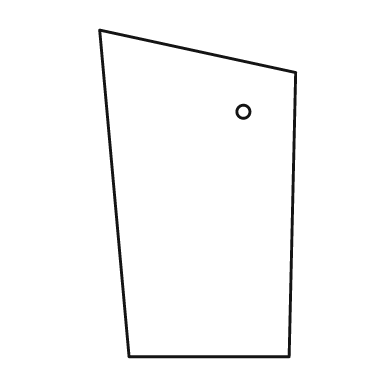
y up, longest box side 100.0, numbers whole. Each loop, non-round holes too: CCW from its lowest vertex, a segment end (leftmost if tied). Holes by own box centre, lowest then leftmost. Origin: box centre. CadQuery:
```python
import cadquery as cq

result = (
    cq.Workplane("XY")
    .moveTo(-21.0, -50.0)
    .lineTo(28.0, -50.0)
    .lineTo(30.0, 37.0)
    .lineTo(-30.0, 50.0)
    .close()
    .moveTo(14.0, 25.0)
    .circle(2.0)
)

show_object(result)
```